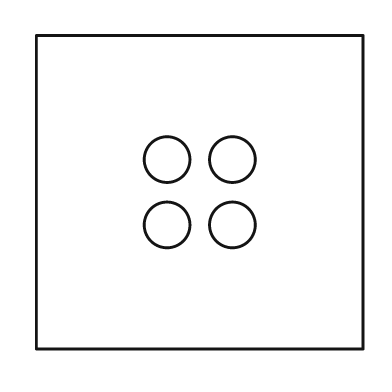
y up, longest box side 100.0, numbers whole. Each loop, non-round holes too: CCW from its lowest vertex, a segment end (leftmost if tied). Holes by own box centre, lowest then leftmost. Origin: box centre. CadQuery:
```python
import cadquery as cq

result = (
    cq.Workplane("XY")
    .moveTo(-50.0, -48.0)
    .lineTo(50.0, -48.0)
    .lineTo(50.0, 48.0)
    .lineTo(-50.0, 48.0)
    .close()
    .moveTo(-10.0, -10.0)
    .circle(7.0)
    .moveTo(10.0, -10.0)
    .circle(7.0)
    .moveTo(-10.0, 10.0)
    .circle(7.0)
    .moveTo(10.0, 10.0)
    .circle(7.0)
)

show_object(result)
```